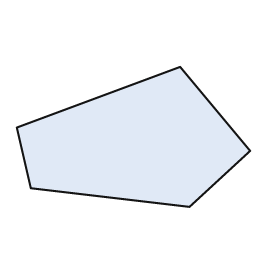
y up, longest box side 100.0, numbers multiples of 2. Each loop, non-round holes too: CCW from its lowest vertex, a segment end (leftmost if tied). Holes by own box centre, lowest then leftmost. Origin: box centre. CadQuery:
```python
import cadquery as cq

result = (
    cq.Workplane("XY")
    .moveTo(24.0, -30.0)
    .lineTo(50.0, -6.0)
    .lineTo(20.0, 30.0)
    .lineTo(-50.0, 4.0)
    .lineTo(-44.0, -22.0)
    .close()
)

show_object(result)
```